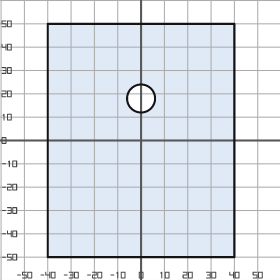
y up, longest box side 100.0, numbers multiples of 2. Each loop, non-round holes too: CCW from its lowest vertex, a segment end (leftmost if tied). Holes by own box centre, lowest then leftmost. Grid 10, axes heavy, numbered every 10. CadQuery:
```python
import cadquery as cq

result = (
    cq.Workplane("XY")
    .moveTo(-40.0, -50.0)
    .lineTo(40.0, -50.0)
    .lineTo(40.0, 50.0)
    .lineTo(-40.0, 50.0)
    .close()
    .moveTo(0.0, 18.0)
    .circle(6.0)
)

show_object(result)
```